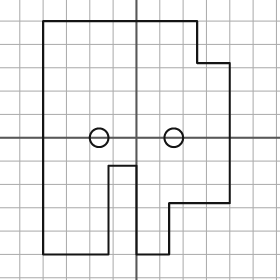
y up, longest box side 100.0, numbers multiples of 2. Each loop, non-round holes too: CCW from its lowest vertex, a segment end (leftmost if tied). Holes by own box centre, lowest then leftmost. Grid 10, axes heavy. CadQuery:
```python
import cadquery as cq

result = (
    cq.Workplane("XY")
    .moveTo(-40.0, -50.0)
    .lineTo(-12.0, -50.0)
    .lineTo(-12.0, -12.0)
    .lineTo(0.0, -12.0)
    .lineTo(0.0, -50.0)
    .lineTo(14.0, -50.0)
    .lineTo(14.0, -28.0)
    .lineTo(40.0, -28.0)
    .lineTo(40.0, 32.0)
    .lineTo(26.0, 32.0)
    .lineTo(26.0, 50.0)
    .lineTo(-40.0, 50.0)
    .close()
    .moveTo(-16.0, 0.0)
    .circle(4.0)
    .moveTo(16.0, 0.0)
    .circle(4.0)
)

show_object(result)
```